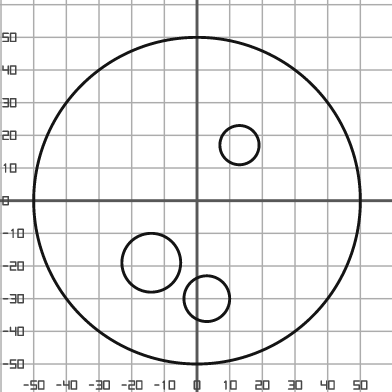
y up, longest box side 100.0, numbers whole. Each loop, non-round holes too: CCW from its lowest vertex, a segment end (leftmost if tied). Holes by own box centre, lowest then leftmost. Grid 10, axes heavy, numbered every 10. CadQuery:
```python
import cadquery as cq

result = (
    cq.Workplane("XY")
    .moveTo(0.0, 0.0)
    .circle(50.0)
    .moveTo(3.0, -30.0)
    .circle(7.0)
    .moveTo(-14.0, -19.0)
    .circle(9.0)
    .moveTo(13.0, 17.0)
    .circle(6.0)
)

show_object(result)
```